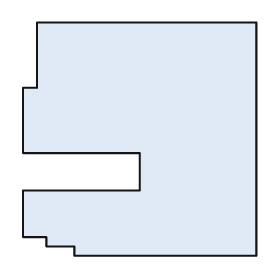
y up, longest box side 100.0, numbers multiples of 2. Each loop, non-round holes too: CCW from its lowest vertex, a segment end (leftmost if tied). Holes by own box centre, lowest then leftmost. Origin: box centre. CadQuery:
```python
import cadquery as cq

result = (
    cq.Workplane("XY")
    .moveTo(-28.0, -50.0)
    .lineTo(50.0, -50.0)
    .lineTo(50.0, 50.0)
    .lineTo(-44.0, 50.0)
    .lineTo(-44.0, 22.0)
    .lineTo(-50.0, 22.0)
    .lineTo(-50.0, -6.0)
    .lineTo(0.0, -6.0)
    .lineTo(0.0, -22.0)
    .lineTo(-50.0, -22.0)
    .lineTo(-50.0, -42.0)
    .lineTo(-40.0, -42.0)
    .lineTo(-40.0, -46.0)
    .lineTo(-28.0, -46.0)
    .close()
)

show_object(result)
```